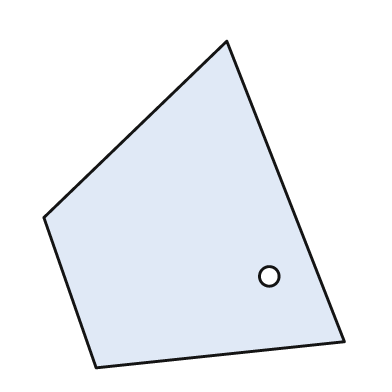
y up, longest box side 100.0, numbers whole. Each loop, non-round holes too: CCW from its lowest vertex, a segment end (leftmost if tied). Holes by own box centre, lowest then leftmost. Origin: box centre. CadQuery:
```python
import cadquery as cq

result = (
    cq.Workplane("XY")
    .moveTo(-30.0, -50.0)
    .lineTo(46.0, -42.0)
    .lineTo(10.0, 50.0)
    .lineTo(-46.0, -4.0)
    .close()
    .moveTo(23.0, -22.0)
    .circle(3.0)
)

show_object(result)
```